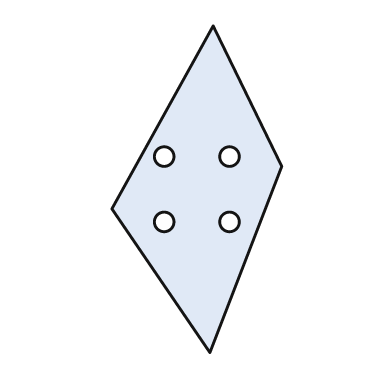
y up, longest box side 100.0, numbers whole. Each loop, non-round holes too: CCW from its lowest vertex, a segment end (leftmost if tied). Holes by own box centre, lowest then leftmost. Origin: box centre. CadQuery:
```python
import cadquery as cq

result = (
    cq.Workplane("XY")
    .moveTo(4.0, -50.0)
    .lineTo(26.0, 7.0)
    .lineTo(5.0, 50.0)
    .lineTo(-26.0, -6.0)
    .close()
    .moveTo(-10.0, -10.0)
    .circle(3.0)
    .moveTo(10.0, -10.0)
    .circle(3.0)
    .moveTo(-10.0, 10.0)
    .circle(3.0)
    .moveTo(10.0, 10.0)
    .circle(3.0)
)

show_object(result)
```